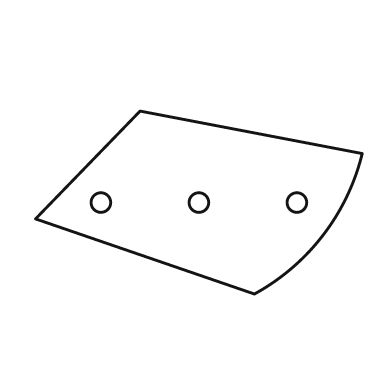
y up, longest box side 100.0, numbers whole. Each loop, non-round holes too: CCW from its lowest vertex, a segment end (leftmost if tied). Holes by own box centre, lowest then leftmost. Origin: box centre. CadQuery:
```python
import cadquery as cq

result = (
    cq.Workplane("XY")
    .moveTo(17.0, -28.0)
    .threePointArc((38.0, -10.0), (50.0, 15.0))
    .lineTo(-18.0, 28.0)
    .lineTo(-50.0, -5.0)
    .close()
    .moveTo(-30.0, 0.0)
    .circle(3.0)
    .moveTo(0.0, 0.0)
    .circle(3.0)
    .moveTo(30.0, 0.0)
    .circle(3.0)
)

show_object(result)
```